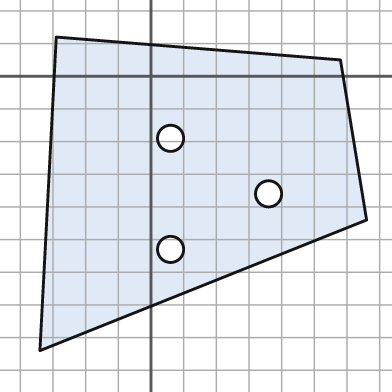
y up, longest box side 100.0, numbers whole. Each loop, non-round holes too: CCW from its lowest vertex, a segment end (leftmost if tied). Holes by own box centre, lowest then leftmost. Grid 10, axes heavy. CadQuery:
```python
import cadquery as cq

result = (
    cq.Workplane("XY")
    .moveTo(-34.0, -84.0)
    .lineTo(66.0, -44.0)
    .lineTo(58.0, 5.0)
    .lineTo(-29.0, 12.0)
    .close()
    .moveTo(6.0, -53.0)
    .circle(4.0)
    .moveTo(36.0, -36.0)
    .circle(4.0)
    .moveTo(6.0, -19.0)
    .circle(4.0)
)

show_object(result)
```